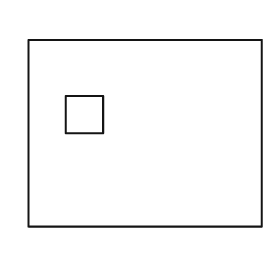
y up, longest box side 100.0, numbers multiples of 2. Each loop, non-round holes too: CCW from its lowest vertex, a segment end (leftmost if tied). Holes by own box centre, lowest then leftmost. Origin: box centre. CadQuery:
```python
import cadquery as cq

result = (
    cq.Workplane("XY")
    .moveTo(-50.0, -40.0)
    .lineTo(50.0, -40.0)
    .lineTo(50.0, 40.0)
    .lineTo(-50.0, 40.0)
    .close()
    .moveTo(-34.0, 0.0)
    .lineTo(-18.0, 0.0)
    .lineTo(-18.0, 16.0)
    .lineTo(-34.0, 16.0)
    .close()
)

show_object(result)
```